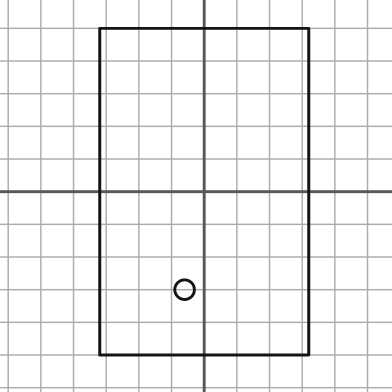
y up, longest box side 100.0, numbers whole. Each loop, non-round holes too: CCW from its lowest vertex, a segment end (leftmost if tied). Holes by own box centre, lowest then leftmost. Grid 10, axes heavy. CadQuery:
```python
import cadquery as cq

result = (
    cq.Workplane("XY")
    .moveTo(-32.0, -50.0)
    .lineTo(32.0, -50.0)
    .lineTo(32.0, 50.0)
    .lineTo(-32.0, 50.0)
    .close()
    .moveTo(-6.0, -30.0)
    .circle(3.0)
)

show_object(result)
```